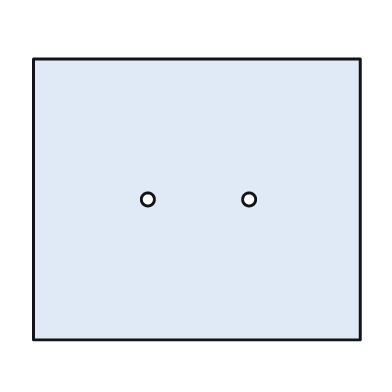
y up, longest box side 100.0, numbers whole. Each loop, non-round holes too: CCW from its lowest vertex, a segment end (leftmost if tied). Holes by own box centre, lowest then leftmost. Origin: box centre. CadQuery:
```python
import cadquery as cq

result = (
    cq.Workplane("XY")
    .moveTo(-50.0, -43.0)
    .lineTo(50.0, -43.0)
    .lineTo(50.0, 43.0)
    .lineTo(-50.0, 43.0)
    .close()
    .moveTo(-15.0, 0.0)
    .circle(2.0)
    .moveTo(16.0, 0.0)
    .circle(2.0)
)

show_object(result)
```